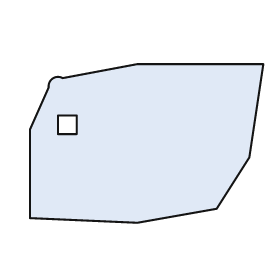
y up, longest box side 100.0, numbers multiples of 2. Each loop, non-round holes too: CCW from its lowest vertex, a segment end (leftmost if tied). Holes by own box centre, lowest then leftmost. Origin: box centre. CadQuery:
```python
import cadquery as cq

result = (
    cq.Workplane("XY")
    .moveTo(-4.0, -34.0)
    .lineTo(30.0, -28.0)
    .lineTo(44.0, -6.0)
    .lineTo(50.0, 34.0)
    .lineTo(-4.0, 34.0)
    .lineTo(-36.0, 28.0)
    .threePointArc((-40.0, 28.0), (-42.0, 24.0))
    .lineTo(-50.0, 6.0)
    .lineTo(-50.0, -32.0)
    .close()
    .moveTo(-38.0, 4.0)
    .lineTo(-30.0, 4.0)
    .lineTo(-30.0, 12.0)
    .lineTo(-38.0, 12.0)
    .close()
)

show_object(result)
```